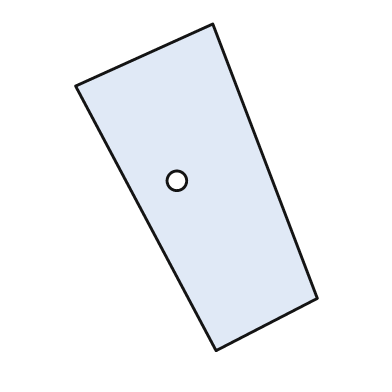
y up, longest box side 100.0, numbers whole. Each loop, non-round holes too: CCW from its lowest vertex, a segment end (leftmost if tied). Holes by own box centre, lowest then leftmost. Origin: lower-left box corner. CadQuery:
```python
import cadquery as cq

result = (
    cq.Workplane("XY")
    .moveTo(43.0, 0.0)
    .lineTo(74.0, 16.0)
    .lineTo(42.0, 100.0)
    .lineTo(0.0, 81.0)
    .close()
    .moveTo(31.0, 52.0)
    .circle(3.0)
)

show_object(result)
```